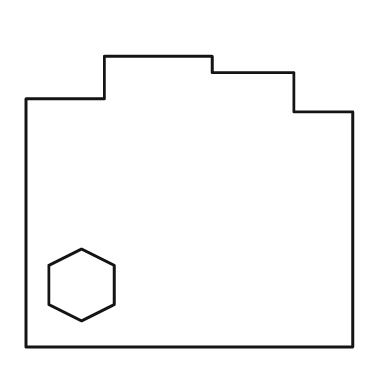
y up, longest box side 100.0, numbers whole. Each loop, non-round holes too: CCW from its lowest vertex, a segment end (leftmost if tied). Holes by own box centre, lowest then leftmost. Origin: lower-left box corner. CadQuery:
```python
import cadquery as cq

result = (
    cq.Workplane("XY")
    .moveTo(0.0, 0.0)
    .lineTo(100.0, 0.0)
    .lineTo(100.0, 72.0)
    .lineTo(82.0, 72.0)
    .lineTo(82.0, 84.0)
    .lineTo(57.0, 84.0)
    .lineTo(57.0, 89.0)
    .lineTo(24.0, 89.0)
    .lineTo(24.0, 76.0)
    .lineTo(0.0, 76.0)
    .close()
    .moveTo(17.0, 8.0)
    .lineTo(27.0, 13.0)
    .lineTo(27.0, 25.0)
    .lineTo(17.0, 30.0)
    .lineTo(7.0, 25.0)
    .lineTo(7.0, 13.0)
    .close()
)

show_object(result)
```